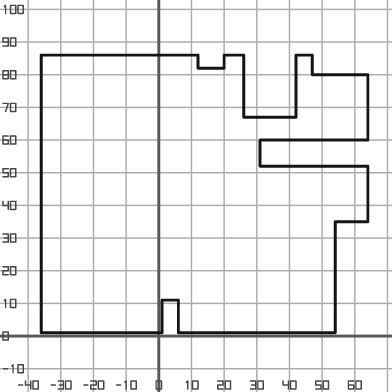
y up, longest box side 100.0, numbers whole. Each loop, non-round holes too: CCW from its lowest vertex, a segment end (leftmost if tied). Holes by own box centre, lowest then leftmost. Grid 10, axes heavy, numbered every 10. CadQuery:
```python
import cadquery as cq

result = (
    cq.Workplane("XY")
    .moveTo(-36.0, 1.0)
    .lineTo(1.0, 1.0)
    .lineTo(1.0, 11.0)
    .lineTo(6.0, 11.0)
    .lineTo(6.0, 1.0)
    .lineTo(54.0, 1.0)
    .lineTo(54.0, 35.0)
    .lineTo(64.0, 35.0)
    .lineTo(64.0, 52.0)
    .lineTo(31.0, 52.0)
    .lineTo(31.0, 60.0)
    .lineTo(64.0, 60.0)
    .lineTo(64.0, 80.0)
    .lineTo(47.0, 80.0)
    .lineTo(47.0, 86.0)
    .lineTo(42.0, 86.0)
    .lineTo(42.0, 67.0)
    .lineTo(26.0, 67.0)
    .lineTo(26.0, 86.0)
    .lineTo(20.0, 86.0)
    .lineTo(20.0, 82.0)
    .lineTo(12.0, 82.0)
    .lineTo(12.0, 86.0)
    .lineTo(-36.0, 86.0)
    .close()
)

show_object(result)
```